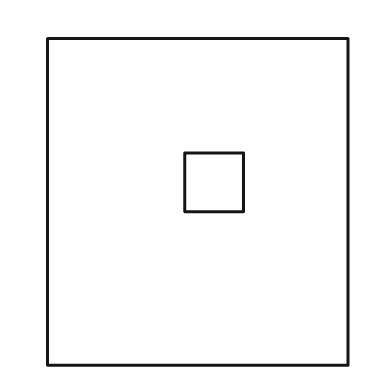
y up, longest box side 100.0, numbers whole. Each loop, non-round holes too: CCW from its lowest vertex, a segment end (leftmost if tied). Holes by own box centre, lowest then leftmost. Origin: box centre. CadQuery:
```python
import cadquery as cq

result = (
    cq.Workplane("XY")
    .moveTo(-46.0, -50.0)
    .lineTo(46.0, -50.0)
    .lineTo(46.0, 50.0)
    .lineTo(-46.0, 50.0)
    .close()
    .moveTo(-4.0, -3.0)
    .lineTo(14.0, -3.0)
    .lineTo(14.0, 15.0)
    .lineTo(-4.0, 15.0)
    .close()
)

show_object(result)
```